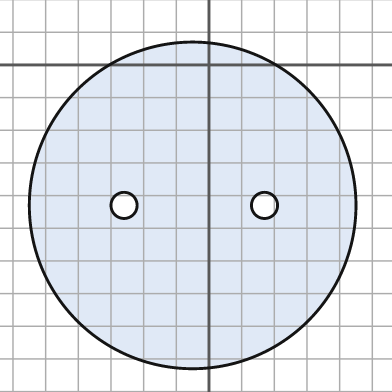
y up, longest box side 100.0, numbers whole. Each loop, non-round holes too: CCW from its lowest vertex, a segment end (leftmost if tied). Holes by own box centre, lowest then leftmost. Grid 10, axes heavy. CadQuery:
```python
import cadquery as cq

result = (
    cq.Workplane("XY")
    .moveTo(-5.0, -43.0)
    .circle(50.0)
    .moveTo(-26.0, -43.0)
    .circle(4.0)
    .moveTo(17.0, -43.0)
    .circle(4.0)
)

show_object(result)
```